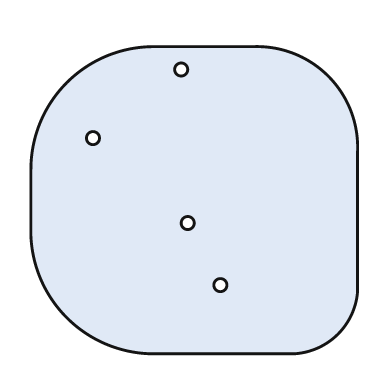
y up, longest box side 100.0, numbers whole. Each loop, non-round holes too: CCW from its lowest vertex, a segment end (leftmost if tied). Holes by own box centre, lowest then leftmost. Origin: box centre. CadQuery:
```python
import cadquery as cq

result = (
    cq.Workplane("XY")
    .moveTo(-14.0, -47.0)
    .lineTo(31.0, -47.0)
    .threePointArc((44.0, -41.0), (50.0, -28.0))
    .lineTo(50.0, 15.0)
    .threePointArc((41.0, 38.0), (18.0, 47.0))
    .lineTo(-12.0, 47.0)
    .threePointArc((-39.0, 36.0), (-50.0, 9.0))
    .lineTo(-50.0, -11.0)
    .threePointArc((-39.0, -36.0), (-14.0, -47.0))
    .close()
    .moveTo(8.0, -26.0)
    .circle(2.0)
    .moveTo(-2.0, -7.0)
    .circle(2.0)
    .moveTo(-31.0, 19.0)
    .circle(2.0)
    .moveTo(-4.0, 40.0)
    .circle(2.0)
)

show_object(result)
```